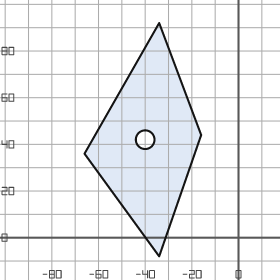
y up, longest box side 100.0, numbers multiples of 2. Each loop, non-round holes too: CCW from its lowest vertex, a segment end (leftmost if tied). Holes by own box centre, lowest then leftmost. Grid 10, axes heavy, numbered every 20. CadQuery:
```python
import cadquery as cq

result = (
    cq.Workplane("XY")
    .moveTo(-34.0, -8.0)
    .lineTo(-16.0, 44.0)
    .lineTo(-34.0, 92.0)
    .lineTo(-66.0, 36.0)
    .close()
    .moveTo(-40.0, 42.0)
    .circle(4.0)
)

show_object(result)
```